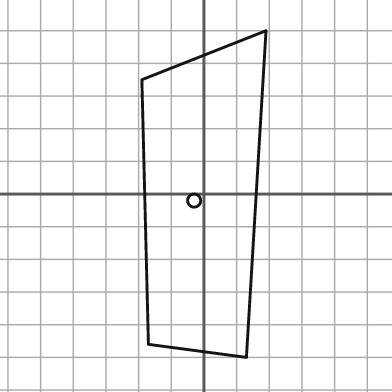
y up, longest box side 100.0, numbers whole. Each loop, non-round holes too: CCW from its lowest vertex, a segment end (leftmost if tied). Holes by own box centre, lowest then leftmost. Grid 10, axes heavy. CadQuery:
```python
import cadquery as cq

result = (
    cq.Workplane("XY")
    .moveTo(13.0, -50.0)
    .lineTo(19.0, 50.0)
    .lineTo(-19.0, 35.0)
    .lineTo(-17.0, -46.0)
    .close()
    .moveTo(-3.0, -2.0)
    .circle(2.0)
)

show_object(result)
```